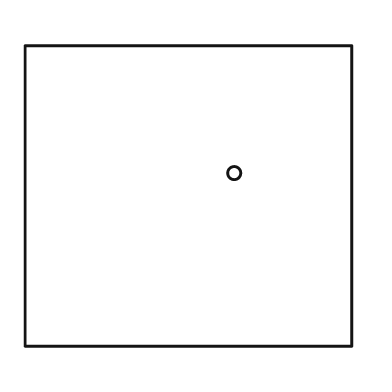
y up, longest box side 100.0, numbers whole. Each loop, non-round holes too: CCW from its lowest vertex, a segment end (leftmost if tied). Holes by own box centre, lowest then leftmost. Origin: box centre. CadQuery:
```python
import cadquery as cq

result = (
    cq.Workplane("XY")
    .moveTo(-50.0, -46.0)
    .lineTo(50.0, -46.0)
    .lineTo(50.0, 46.0)
    .lineTo(-50.0, 46.0)
    .close()
    .moveTo(14.0, 7.0)
    .circle(2.0)
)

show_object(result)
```